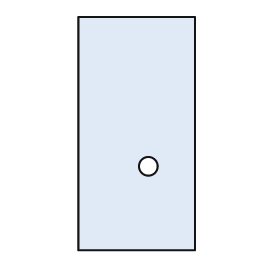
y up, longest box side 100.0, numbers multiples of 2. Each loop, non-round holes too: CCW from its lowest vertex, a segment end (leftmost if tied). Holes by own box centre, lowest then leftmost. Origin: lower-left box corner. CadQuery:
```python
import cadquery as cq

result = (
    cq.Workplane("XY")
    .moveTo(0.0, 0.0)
    .lineTo(50.0, 0.0)
    .lineTo(50.0, 100.0)
    .lineTo(0.0, 100.0)
    .close()
    .moveTo(30.0, 36.0)
    .circle(4.0)
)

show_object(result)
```